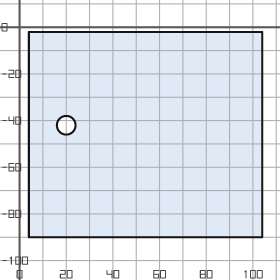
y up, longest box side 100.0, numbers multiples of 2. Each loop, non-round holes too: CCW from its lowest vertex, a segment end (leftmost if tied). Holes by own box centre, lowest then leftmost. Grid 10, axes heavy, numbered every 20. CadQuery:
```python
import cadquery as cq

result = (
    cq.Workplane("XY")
    .moveTo(4.0, -90.0)
    .lineTo(104.0, -90.0)
    .lineTo(104.0, -2.0)
    .lineTo(4.0, -2.0)
    .close()
    .moveTo(20.0, -42.0)
    .circle(4.0)
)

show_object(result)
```